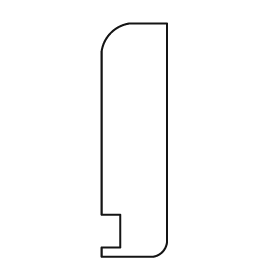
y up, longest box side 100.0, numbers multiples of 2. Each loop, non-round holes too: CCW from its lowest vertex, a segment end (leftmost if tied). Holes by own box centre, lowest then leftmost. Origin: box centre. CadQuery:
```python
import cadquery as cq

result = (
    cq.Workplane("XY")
    .moveTo(-14.0, -50.0)
    .lineTo(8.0, -50.0)
    .threePointArc((12.0, -48.0), (14.0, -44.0))
    .lineTo(14.0, 50.0)
    .lineTo(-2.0, 50.0)
    .threePointArc((-10.0, 46.0), (-14.0, 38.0))
    .lineTo(-14.0, -32.0)
    .lineTo(-6.0, -32.0)
    .lineTo(-6.0, -46.0)
    .lineTo(-14.0, -46.0)
    .close()
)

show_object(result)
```